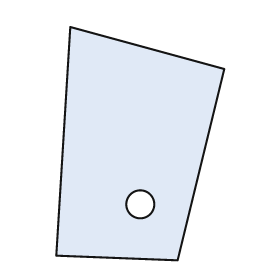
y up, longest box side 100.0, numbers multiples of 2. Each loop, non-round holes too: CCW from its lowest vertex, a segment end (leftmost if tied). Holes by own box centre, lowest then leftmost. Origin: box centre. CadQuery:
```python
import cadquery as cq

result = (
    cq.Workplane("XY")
    .moveTo(16.0, -50.0)
    .lineTo(36.0, 32.0)
    .lineTo(-30.0, 50.0)
    .lineTo(-36.0, -48.0)
    .close()
    .moveTo(0.0, -26.0)
    .circle(6.0)
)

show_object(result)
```